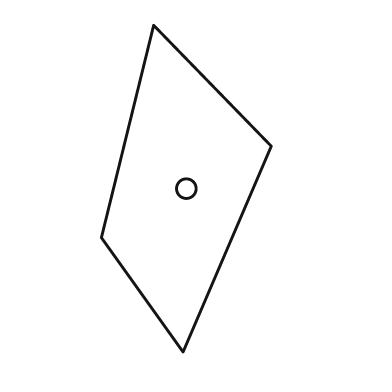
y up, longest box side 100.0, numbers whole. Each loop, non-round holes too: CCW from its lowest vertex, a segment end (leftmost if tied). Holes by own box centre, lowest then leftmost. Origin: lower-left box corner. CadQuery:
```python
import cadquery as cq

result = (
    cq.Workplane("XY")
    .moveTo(25.0, 0.0)
    .lineTo(52.0, 63.0)
    .lineTo(16.0, 100.0)
    .lineTo(0.0, 35.0)
    .close()
    .moveTo(26.0, 50.0)
    .circle(3.0)
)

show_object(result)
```